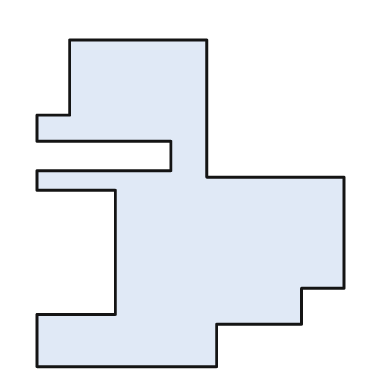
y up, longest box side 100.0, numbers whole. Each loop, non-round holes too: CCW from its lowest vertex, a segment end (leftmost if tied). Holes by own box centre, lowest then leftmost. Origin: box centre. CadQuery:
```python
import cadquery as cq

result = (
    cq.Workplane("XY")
    .moveTo(-47.0, -50.0)
    .lineTo(8.0, -50.0)
    .lineTo(8.0, -37.0)
    .lineTo(34.0, -37.0)
    .lineTo(34.0, -26.0)
    .lineTo(47.0, -26.0)
    .lineTo(47.0, 8.0)
    .lineTo(5.0, 8.0)
    .lineTo(5.0, 50.0)
    .lineTo(-37.0, 50.0)
    .lineTo(-37.0, 27.0)
    .lineTo(-47.0, 27.0)
    .lineTo(-47.0, 19.0)
    .lineTo(-6.0, 19.0)
    .lineTo(-6.0, 10.0)
    .lineTo(-47.0, 10.0)
    .lineTo(-47.0, 4.0)
    .lineTo(-23.0, 4.0)
    .lineTo(-23.0, -34.0)
    .lineTo(-47.0, -34.0)
    .close()
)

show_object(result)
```